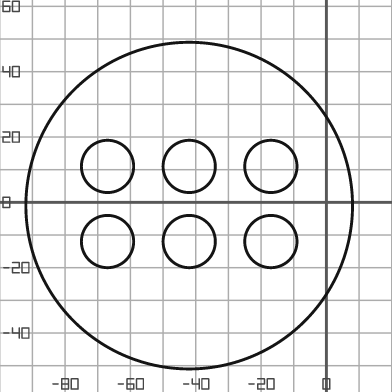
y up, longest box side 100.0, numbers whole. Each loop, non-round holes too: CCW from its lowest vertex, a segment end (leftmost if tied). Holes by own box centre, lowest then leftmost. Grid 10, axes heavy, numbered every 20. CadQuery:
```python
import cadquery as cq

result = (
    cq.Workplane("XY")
    .moveTo(-42.0, -1.0)
    .circle(50.0)
    .moveTo(-67.0, -12.0)
    .circle(8.0)
    .moveTo(-42.0, -12.0)
    .circle(8.0)
    .moveTo(-17.0, -12.0)
    .circle(8.0)
    .moveTo(-67.0, 11.0)
    .circle(8.0)
    .moveTo(-42.0, 11.0)
    .circle(8.0)
    .moveTo(-17.0, 11.0)
    .circle(8.0)
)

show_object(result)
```